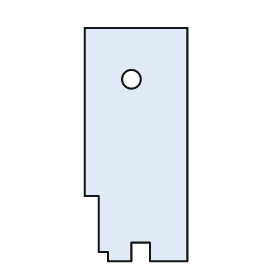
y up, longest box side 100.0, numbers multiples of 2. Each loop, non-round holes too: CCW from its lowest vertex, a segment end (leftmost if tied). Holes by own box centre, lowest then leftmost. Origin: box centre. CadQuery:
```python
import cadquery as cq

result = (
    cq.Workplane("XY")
    .moveTo(-12.0, -50.0)
    .lineTo(-2.0, -50.0)
    .lineTo(-2.0, -42.0)
    .lineTo(6.0, -42.0)
    .lineTo(6.0, -50.0)
    .lineTo(22.0, -50.0)
    .lineTo(22.0, 50.0)
    .lineTo(-22.0, 50.0)
    .lineTo(-22.0, -22.0)
    .lineTo(-16.0, -22.0)
    .lineTo(-16.0, -46.0)
    .lineTo(-12.0, -46.0)
    .close()
    .moveTo(-2.0, 28.0)
    .circle(4.0)
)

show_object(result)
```